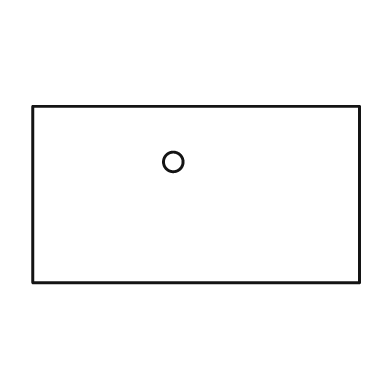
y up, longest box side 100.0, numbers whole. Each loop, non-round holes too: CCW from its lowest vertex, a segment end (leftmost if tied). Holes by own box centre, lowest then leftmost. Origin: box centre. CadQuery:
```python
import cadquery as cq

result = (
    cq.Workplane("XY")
    .moveTo(-50.0, -27.0)
    .lineTo(50.0, -27.0)
    .lineTo(50.0, 27.0)
    .lineTo(-50.0, 27.0)
    .close()
    .moveTo(-7.0, 10.0)
    .circle(3.0)
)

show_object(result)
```